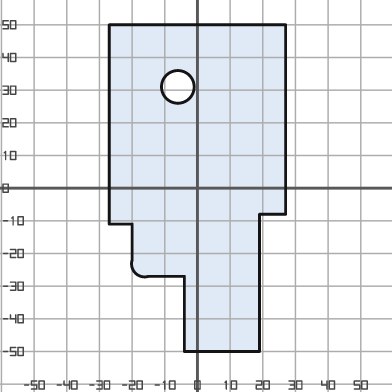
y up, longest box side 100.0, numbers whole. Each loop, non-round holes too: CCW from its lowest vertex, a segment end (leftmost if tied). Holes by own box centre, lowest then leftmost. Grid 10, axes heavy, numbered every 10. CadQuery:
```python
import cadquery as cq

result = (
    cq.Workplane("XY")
    .moveTo(-4.0, -50.0)
    .lineTo(19.0, -50.0)
    .lineTo(19.0, -8.0)
    .lineTo(27.0, -8.0)
    .lineTo(27.0, 50.0)
    .lineTo(-27.0, 50.0)
    .lineTo(-27.0, -11.0)
    .lineTo(-20.0, -11.0)
    .lineTo(-20.0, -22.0)
    .threePointArc((-19.0, -26.0), (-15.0, -27.0))
    .lineTo(-4.0, -27.0)
    .close()
    .moveTo(-6.0, 31.0)
    .circle(5.0)
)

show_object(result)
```